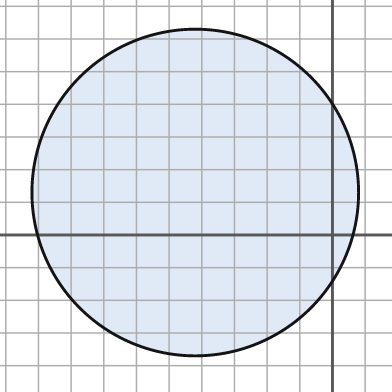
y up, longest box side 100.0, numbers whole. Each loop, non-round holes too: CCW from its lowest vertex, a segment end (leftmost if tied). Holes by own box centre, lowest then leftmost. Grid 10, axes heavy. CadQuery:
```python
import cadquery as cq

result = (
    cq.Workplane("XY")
    .moveTo(-42.0, 13.0)
    .circle(50.0)
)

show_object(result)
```